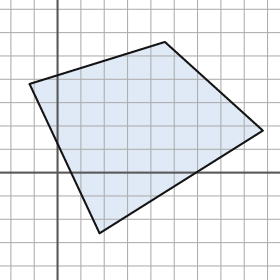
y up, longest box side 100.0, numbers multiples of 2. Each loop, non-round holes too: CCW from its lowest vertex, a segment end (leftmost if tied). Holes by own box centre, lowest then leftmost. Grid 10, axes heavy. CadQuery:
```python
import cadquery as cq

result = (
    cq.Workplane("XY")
    .moveTo(18.0, -26.0)
    .lineTo(88.0, 18.0)
    .lineTo(46.0, 56.0)
    .lineTo(-12.0, 38.0)
    .close()
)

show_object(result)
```